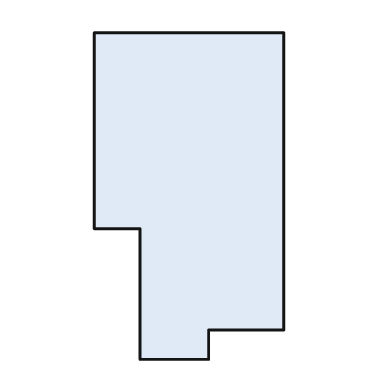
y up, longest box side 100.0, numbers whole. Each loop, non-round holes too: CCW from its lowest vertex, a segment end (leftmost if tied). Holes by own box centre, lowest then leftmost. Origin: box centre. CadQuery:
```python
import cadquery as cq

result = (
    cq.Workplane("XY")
    .moveTo(-15.0, -50.0)
    .lineTo(6.0, -50.0)
    .lineTo(6.0, -41.0)
    .lineTo(29.0, -41.0)
    .lineTo(29.0, 50.0)
    .lineTo(-29.0, 50.0)
    .lineTo(-29.0, -10.0)
    .lineTo(-15.0, -10.0)
    .close()
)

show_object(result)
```